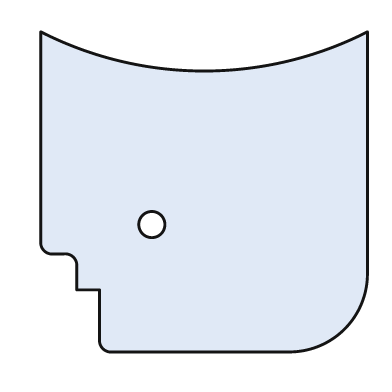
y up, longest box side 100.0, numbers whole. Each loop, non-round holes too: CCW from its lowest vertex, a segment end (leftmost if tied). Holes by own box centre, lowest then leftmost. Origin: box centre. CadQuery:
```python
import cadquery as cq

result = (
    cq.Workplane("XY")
    .moveTo(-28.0, -49.0)
    .lineTo(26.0, -49.0)
    .threePointArc((43.0, -42.0), (50.0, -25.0))
    .lineTo(50.0, 49.0)
    .threePointArc((0.0, 37.0), (-50.0, 49.0))
    .lineTo(-50.0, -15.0)
    .threePointArc((-49.0, -18.0), (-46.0, -19.0))
    .lineTo(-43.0, -19.0)
    .threePointArc((-40.0, -20.0), (-39.0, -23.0))
    .lineTo(-39.0, -30.0)
    .lineTo(-32.0, -30.0)
    .lineTo(-32.0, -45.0)
    .threePointArc((-31.0, -48.0), (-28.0, -49.0))
    .close()
    .moveTo(-16.0, -10.0)
    .circle(4.0)
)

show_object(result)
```